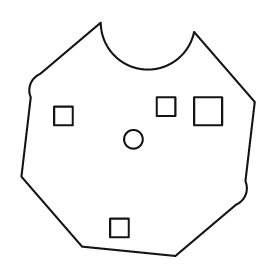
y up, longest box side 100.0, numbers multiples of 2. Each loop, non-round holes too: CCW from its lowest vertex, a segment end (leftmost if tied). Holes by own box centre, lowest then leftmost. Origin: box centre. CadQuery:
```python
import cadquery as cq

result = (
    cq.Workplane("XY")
    .moveTo(16.0, -50.0)
    .lineTo(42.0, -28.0)
    .threePointArc((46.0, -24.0), (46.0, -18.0))
    .lineTo(50.0, 16.0)
    .lineTo(24.0, 46.0)
    .threePointArc((2.0, 30.0), (-16.0, 50.0))
    .lineTo(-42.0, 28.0)
    .threePointArc((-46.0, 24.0), (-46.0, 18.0))
    .lineTo(-50.0, -16.0)
    .lineTo(-24.0, -46.0)
    .close()
    .moveTo(-12.0, -42.0)
    .lineTo(-4.0, -42.0)
    .lineTo(-4.0, -34.0)
    .lineTo(-12.0, -34.0)
    .close()
    .moveTo(-2.0, 0.0)
    .circle(4.0)
    .moveTo(-36.0, 6.0)
    .lineTo(-28.0, 6.0)
    .lineTo(-28.0, 14.0)
    .lineTo(-36.0, 14.0)
    .close()
    .moveTo(24.0, 6.0)
    .lineTo(36.0, 6.0)
    .lineTo(36.0, 18.0)
    .lineTo(24.0, 18.0)
    .close()
    .moveTo(8.0, 10.0)
    .lineTo(16.0, 10.0)
    .lineTo(16.0, 18.0)
    .lineTo(8.0, 18.0)
    .close()
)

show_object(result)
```